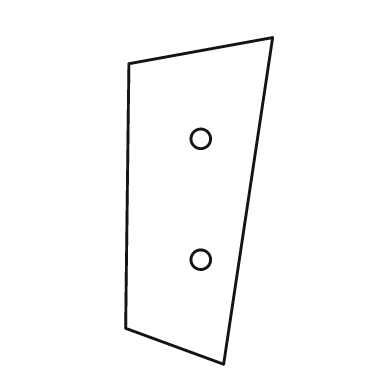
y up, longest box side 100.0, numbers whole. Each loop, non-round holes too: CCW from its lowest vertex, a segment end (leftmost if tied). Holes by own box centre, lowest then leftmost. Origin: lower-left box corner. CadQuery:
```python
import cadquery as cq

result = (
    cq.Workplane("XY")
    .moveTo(30.0, 0.0)
    .lineTo(45.0, 100.0)
    .lineTo(1.0, 92.0)
    .lineTo(0.0, 11.0)
    .close()
    .moveTo(23.0, 32.0)
    .circle(3.0)
    .moveTo(23.0, 69.0)
    .circle(3.0)
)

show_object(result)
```